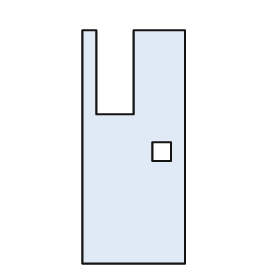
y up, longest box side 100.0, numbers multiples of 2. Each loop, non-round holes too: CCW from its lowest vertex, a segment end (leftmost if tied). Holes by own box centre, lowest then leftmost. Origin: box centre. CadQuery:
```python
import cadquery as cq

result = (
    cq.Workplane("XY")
    .moveTo(-22.0, -50.0)
    .lineTo(22.0, -50.0)
    .lineTo(22.0, 50.0)
    .lineTo(0.0, 50.0)
    .lineTo(0.0, 14.0)
    .lineTo(-16.0, 14.0)
    .lineTo(-16.0, 50.0)
    .lineTo(-22.0, 50.0)
    .close()
    .moveTo(8.0, -6.0)
    .lineTo(16.0, -6.0)
    .lineTo(16.0, 2.0)
    .lineTo(8.0, 2.0)
    .close()
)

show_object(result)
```